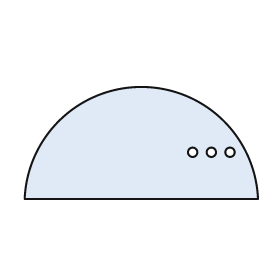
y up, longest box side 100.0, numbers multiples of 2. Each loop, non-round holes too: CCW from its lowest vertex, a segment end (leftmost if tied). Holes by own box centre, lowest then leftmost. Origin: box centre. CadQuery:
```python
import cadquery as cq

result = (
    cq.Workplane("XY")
    .moveTo(-50.0, -24.0)
    .lineTo(50.0, -24.0)
    .threePointArc((0.0, 24.0), (-50.0, -24.0))
    .close()
    .moveTo(22.0, -4.0)
    .circle(2.0)
    .moveTo(30.0, -4.0)
    .circle(2.0)
    .moveTo(38.0, -4.0)
    .circle(2.0)
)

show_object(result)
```